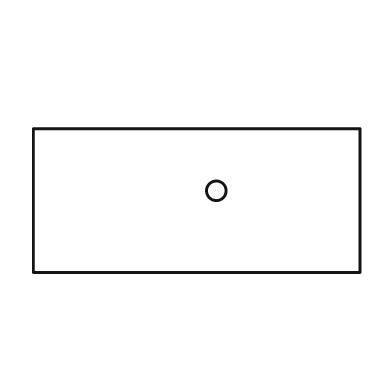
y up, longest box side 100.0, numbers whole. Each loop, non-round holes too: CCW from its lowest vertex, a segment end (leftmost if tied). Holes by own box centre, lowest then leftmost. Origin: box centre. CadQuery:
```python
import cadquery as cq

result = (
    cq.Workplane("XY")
    .moveTo(-50.0, -22.0)
    .lineTo(50.0, -22.0)
    .lineTo(50.0, 22.0)
    .lineTo(-50.0, 22.0)
    .close()
    .moveTo(6.0, 3.0)
    .circle(3.0)
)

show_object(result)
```